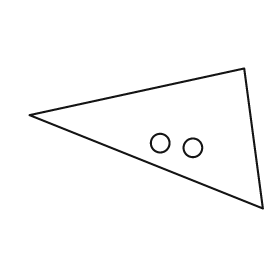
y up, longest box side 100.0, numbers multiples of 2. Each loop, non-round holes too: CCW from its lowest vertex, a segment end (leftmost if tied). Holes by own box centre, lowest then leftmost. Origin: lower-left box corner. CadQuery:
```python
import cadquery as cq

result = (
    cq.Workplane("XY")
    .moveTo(100.0, 0.0)
    .lineTo(92.0, 60.0)
    .lineTo(0.0, 40.0)
    .close()
    .moveTo(70.0, 26.0)
    .circle(4.0)
    .moveTo(56.0, 28.0)
    .circle(4.0)
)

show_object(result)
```